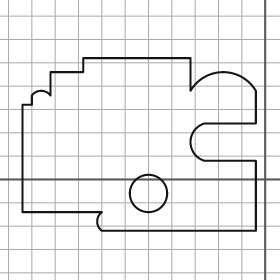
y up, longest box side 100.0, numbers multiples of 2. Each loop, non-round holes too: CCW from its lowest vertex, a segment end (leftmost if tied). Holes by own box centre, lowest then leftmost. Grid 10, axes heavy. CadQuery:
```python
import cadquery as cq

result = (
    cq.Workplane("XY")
    .moveTo(-70.0, -22.0)
    .lineTo(-4.0, -22.0)
    .lineTo(-4.0, 8.0)
    .lineTo(-26.0, 8.0)
    .threePointArc((-32.0, 16.0), (-26.0, 24.0))
    .lineTo(-4.0, 24.0)
    .lineTo(-4.0, 38.0)
    .threePointArc((-18.0, 46.0), (-32.0, 38.0))
    .lineTo(-32.0, 52.0)
    .lineTo(-78.0, 52.0)
    .lineTo(-78.0, 46.0)
    .lineTo(-92.0, 46.0)
    .lineTo(-92.0, 36.0)
    .threePointArc((-96.0, 38.0), (-100.0, 36.0))
    .lineTo(-100.0, 32.0)
    .lineTo(-104.0, 32.0)
    .lineTo(-104.0, -14.0)
    .lineTo(-70.0, -14.0)
    .threePointArc((-72.0, -18.0), (-70.0, -22.0))
    .close()
    .moveTo(-50.0, -6.0)
    .circle(8.0)
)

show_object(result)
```